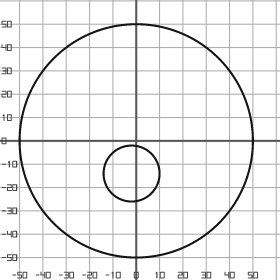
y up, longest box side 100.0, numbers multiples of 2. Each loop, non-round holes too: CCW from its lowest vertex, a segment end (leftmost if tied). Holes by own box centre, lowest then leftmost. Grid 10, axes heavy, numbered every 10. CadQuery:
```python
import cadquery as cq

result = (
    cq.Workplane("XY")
    .moveTo(0.0, 0.0)
    .circle(50.0)
    .moveTo(-2.0, -14.0)
    .circle(12.0)
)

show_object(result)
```